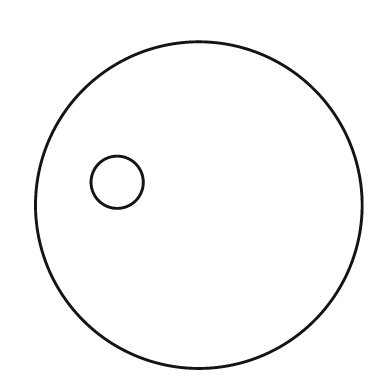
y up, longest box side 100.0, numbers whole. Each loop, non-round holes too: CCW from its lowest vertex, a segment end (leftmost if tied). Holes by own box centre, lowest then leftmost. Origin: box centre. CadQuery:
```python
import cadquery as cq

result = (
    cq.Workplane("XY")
    .moveTo(0.0, 0.0)
    .circle(50.0)
    .moveTo(-25.0, 7.0)
    .circle(8.0)
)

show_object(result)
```